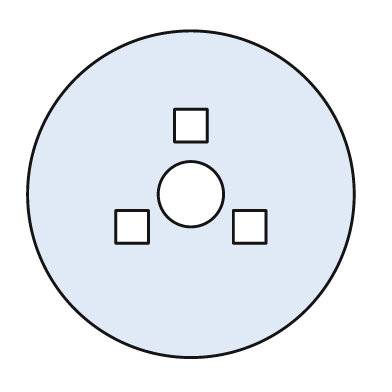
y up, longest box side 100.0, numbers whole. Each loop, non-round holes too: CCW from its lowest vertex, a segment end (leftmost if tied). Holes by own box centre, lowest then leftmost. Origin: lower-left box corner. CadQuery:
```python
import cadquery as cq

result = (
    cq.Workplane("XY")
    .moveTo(50.0, 50.0)
    .circle(50.0)
    .moveTo(27.0, 35.0)
    .lineTo(37.0, 35.0)
    .lineTo(37.0, 45.0)
    .lineTo(27.0, 45.0)
    .close()
    .moveTo(63.0, 35.0)
    .lineTo(73.0, 35.0)
    .lineTo(73.0, 45.0)
    .lineTo(63.0, 45.0)
    .close()
    .moveTo(50.0, 50.0)
    .circle(10.0)
    .moveTo(45.0, 66.0)
    .lineTo(55.0, 66.0)
    .lineTo(55.0, 76.0)
    .lineTo(45.0, 76.0)
    .close()
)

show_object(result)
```